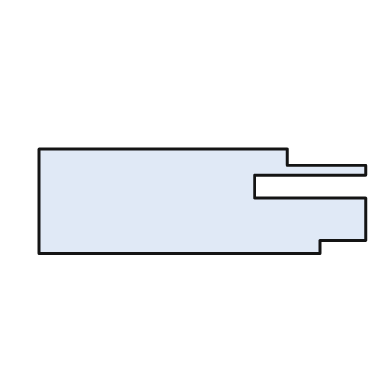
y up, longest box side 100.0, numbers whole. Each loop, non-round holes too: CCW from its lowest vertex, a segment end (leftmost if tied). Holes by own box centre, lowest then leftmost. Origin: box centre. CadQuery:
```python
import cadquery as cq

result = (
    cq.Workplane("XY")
    .moveTo(-50.0, -16.0)
    .lineTo(36.0, -16.0)
    .lineTo(36.0, -12.0)
    .lineTo(50.0, -12.0)
    .lineTo(50.0, 1.0)
    .lineTo(16.0, 1.0)
    .lineTo(16.0, 8.0)
    .lineTo(50.0, 8.0)
    .lineTo(50.0, 11.0)
    .lineTo(26.0, 11.0)
    .lineTo(26.0, 16.0)
    .lineTo(-50.0, 16.0)
    .close()
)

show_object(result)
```